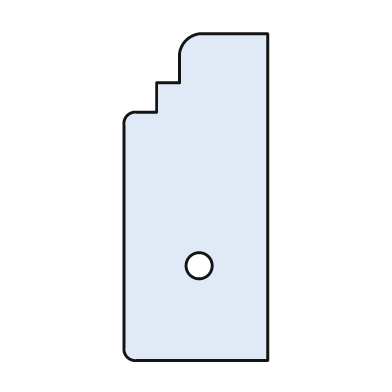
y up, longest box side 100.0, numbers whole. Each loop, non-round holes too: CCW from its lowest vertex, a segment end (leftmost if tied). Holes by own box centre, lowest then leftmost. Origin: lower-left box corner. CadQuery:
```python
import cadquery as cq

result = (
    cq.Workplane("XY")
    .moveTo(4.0, 0.0)
    .lineTo(44.0, 0.0)
    .lineTo(44.0, 100.0)
    .lineTo(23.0, 100.0)
    .threePointArc((19.0, 98.0), (17.0, 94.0))
    .lineTo(17.0, 85.0)
    .lineTo(10.0, 85.0)
    .lineTo(10.0, 76.0)
    .lineTo(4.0, 76.0)
    .threePointArc((1.0, 75.0), (0.0, 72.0))
    .lineTo(0.0, 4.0)
    .threePointArc((1.0, 1.0), (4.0, 0.0))
    .close()
    .moveTo(23.0, 29.0)
    .circle(4.0)
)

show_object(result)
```